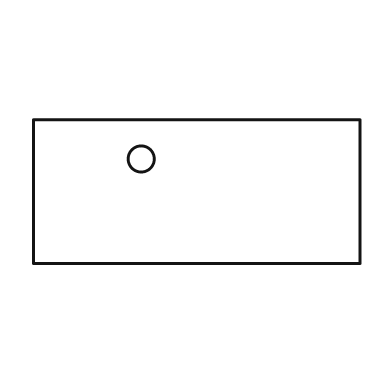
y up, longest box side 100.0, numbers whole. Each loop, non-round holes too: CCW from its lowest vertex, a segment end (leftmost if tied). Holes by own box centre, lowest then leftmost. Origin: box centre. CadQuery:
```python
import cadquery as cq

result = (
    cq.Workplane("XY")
    .moveTo(-50.0, -22.0)
    .lineTo(50.0, -22.0)
    .lineTo(50.0, 22.0)
    .lineTo(-50.0, 22.0)
    .close()
    .moveTo(-17.0, 10.0)
    .circle(4.0)
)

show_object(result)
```